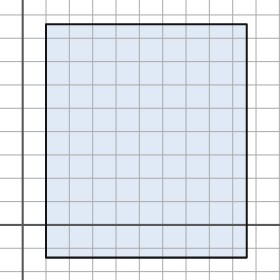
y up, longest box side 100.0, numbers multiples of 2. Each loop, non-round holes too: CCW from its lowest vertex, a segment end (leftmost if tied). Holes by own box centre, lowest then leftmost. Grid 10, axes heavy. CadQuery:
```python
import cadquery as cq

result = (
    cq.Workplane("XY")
    .moveTo(10.0, -14.0)
    .lineTo(96.0, -14.0)
    .lineTo(96.0, 86.0)
    .lineTo(10.0, 86.0)
    .close()
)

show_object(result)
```